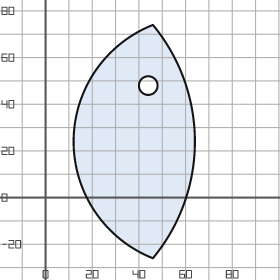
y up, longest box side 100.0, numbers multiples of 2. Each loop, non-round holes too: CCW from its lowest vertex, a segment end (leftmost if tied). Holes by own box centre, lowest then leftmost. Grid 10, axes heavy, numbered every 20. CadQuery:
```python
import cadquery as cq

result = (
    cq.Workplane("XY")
    .moveTo(46.0, -26.0)
    .threePointArc((64.0, 24.0), (46.0, 74.0))
    .threePointArc((12.0, 24.0), (46.0, -26.0))
    .close()
    .moveTo(44.0, 48.0)
    .circle(4.0)
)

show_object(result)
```